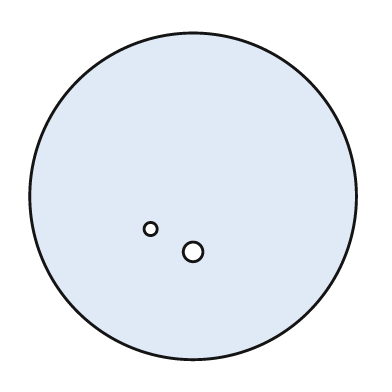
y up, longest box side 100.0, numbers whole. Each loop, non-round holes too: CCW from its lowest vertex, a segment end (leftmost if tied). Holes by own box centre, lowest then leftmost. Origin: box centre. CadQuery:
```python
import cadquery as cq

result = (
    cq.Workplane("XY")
    .moveTo(0.0, 0.0)
    .circle(50.0)
    .moveTo(0.0, -17.0)
    .circle(3.0)
    .moveTo(-13.0, -10.0)
    .circle(2.0)
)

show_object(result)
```